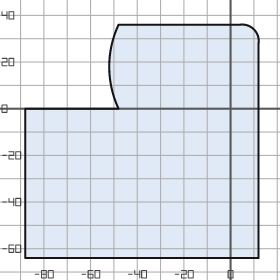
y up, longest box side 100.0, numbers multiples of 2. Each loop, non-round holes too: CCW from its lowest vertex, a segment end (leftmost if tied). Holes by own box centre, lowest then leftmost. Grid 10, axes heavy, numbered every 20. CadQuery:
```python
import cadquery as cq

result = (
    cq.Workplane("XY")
    .moveTo(-88.0, -64.0)
    .lineTo(12.0, -64.0)
    .lineTo(12.0, 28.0)
    .threePointArc((10.0, 34.0), (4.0, 36.0))
    .lineTo(-48.0, 36.0)
    .threePointArc((-52.0, 18.0), (-48.0, 0.0))
    .lineTo(-88.0, 0.0)
    .close()
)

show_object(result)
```